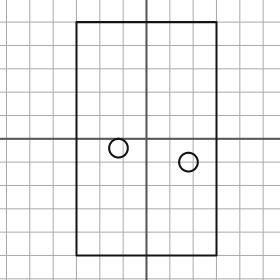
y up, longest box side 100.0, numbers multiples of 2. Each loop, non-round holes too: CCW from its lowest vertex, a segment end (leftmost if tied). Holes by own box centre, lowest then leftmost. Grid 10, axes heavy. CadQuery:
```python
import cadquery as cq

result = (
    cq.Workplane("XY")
    .moveTo(-30.0, -50.0)
    .lineTo(30.0, -50.0)
    .lineTo(30.0, 50.0)
    .lineTo(-30.0, 50.0)
    .close()
    .moveTo(18.0, -10.0)
    .circle(4.0)
    .moveTo(-12.0, -4.0)
    .circle(4.0)
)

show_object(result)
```